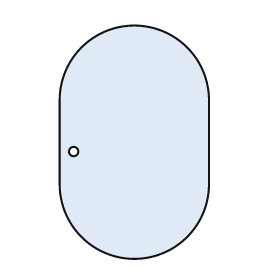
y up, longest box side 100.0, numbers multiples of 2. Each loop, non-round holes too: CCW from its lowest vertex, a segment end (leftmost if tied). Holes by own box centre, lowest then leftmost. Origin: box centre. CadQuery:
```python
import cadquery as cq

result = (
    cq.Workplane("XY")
    .moveTo(-32.0, -18.0)
    .threePointArc((0.0, -50.0), (32.0, -18.0))
    .lineTo(32.0, 18.0)
    .threePointArc((0.0, 50.0), (-32.0, 18.0))
    .close()
    .moveTo(-26.0, -4.0)
    .circle(2.0)
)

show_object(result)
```